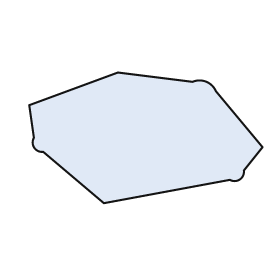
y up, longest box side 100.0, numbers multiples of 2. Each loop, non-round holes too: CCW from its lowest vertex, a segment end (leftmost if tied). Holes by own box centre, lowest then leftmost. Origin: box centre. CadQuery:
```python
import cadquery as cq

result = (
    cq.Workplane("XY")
    .moveTo(-18.0, -28.0)
    .lineTo(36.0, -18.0)
    .threePointArc((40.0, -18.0), (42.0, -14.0))
    .lineTo(50.0, -4.0)
    .lineTo(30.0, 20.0)
    .threePointArc((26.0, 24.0), (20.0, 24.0))
    .lineTo(-12.0, 28.0)
    .lineTo(-50.0, 14.0)
    .lineTo(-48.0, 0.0)
    .threePointArc((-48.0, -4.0), (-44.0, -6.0))
    .close()
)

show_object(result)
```